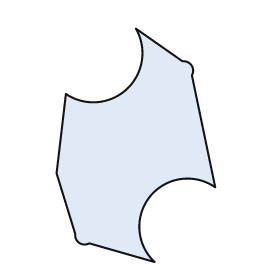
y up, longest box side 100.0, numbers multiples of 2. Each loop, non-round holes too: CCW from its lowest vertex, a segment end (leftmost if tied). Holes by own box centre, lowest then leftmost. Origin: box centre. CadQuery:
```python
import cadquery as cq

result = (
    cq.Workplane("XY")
    .moveTo(8.0, -50.0)
    .threePointArc((6.0, -22.0), (34.0, -18.0))
    .lineTo(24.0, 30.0)
    .threePointArc((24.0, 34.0), (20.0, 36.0))
    .lineTo(0.0, 50.0)
    .threePointArc((-4.0, 24.0), (-30.0, 22.0))
    .lineTo(-34.0, -12.0)
    .lineTo(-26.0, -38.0)
    .threePointArc((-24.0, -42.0), (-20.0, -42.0))
    .close()
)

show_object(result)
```